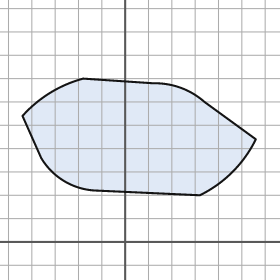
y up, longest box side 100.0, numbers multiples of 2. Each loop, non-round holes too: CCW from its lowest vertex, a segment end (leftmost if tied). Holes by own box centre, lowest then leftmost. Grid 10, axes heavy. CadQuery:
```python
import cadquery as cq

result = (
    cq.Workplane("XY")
    .moveTo(32.0, 20.0)
    .threePointArc((46.0, 30.0), (56.0, 44.0))
    .lineTo(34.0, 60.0)
    .threePointArc((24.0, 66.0), (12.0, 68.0))
    .lineTo(-18.0, 70.0)
    .threePointArc((-32.0, 64.0), (-44.0, 54.0))
    .lineTo(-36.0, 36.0)
    .threePointArc((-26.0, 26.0), (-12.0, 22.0))
    .close()
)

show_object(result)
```